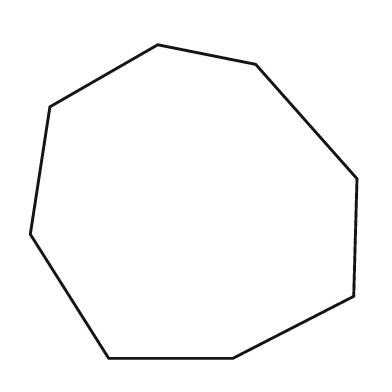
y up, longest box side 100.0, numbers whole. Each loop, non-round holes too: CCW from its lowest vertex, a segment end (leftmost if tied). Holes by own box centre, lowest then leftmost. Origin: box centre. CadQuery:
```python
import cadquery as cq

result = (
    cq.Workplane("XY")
    .moveTo(-26.0, -48.0)
    .lineTo(12.0, -48.0)
    .lineTo(49.0, -29.0)
    .lineTo(50.0, 7.0)
    .lineTo(19.0, 42.0)
    .lineTo(-11.0, 48.0)
    .lineTo(-44.0, 29.0)
    .lineTo(-50.0, -10.0)
    .close()
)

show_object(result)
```